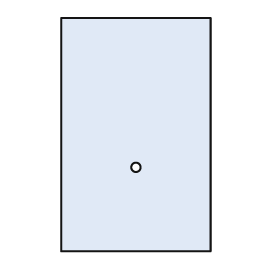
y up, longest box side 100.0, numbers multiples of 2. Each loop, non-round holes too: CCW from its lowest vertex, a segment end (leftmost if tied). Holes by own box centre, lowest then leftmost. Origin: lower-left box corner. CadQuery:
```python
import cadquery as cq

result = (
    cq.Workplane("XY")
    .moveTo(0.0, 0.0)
    .lineTo(64.0, 0.0)
    .lineTo(64.0, 100.0)
    .lineTo(0.0, 100.0)
    .close()
    .moveTo(32.0, 36.0)
    .circle(2.0)
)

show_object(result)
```